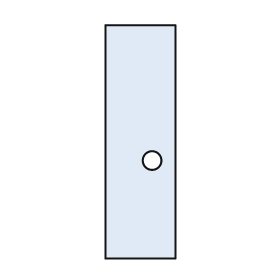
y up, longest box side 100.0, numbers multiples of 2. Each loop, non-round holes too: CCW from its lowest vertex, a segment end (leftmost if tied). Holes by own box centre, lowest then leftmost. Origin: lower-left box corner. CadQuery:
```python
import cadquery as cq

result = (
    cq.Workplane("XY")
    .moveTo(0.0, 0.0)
    .lineTo(30.0, 0.0)
    .lineTo(30.0, 100.0)
    .lineTo(0.0, 100.0)
    .close()
    .moveTo(20.0, 42.0)
    .circle(4.0)
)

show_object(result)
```